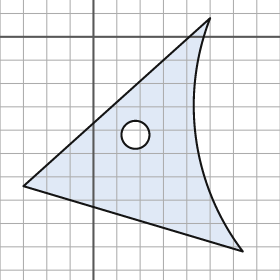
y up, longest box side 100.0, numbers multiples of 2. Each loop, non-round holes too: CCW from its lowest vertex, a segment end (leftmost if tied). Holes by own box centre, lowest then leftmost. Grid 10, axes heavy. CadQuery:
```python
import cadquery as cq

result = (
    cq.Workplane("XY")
    .moveTo(64.0, -92.0)
    .threePointArc((44.0, -44.0), (50.0, 8.0))
    .lineTo(-30.0, -64.0)
    .close()
    .moveTo(18.0, -42.0)
    .circle(6.0)
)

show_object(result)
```